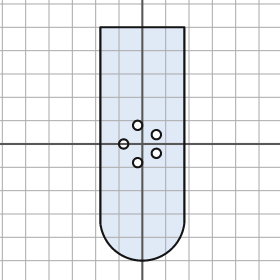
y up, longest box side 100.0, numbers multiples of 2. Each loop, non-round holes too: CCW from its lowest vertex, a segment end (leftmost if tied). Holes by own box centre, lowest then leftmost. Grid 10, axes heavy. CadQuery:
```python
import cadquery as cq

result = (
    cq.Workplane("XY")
    .moveTo(-18.0, -34.0)
    .threePointArc((0.0, -50.0), (18.0, -34.0))
    .lineTo(18.0, 50.0)
    .lineTo(-18.0, 50.0)
    .close()
    .moveTo(-2.0, -8.0)
    .circle(2.0)
    .moveTo(6.0, -4.0)
    .circle(2.0)
    .moveTo(-8.0, 0.0)
    .circle(2.0)
    .moveTo(6.0, 4.0)
    .circle(2.0)
    .moveTo(-2.0, 8.0)
    .circle(2.0)
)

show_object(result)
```